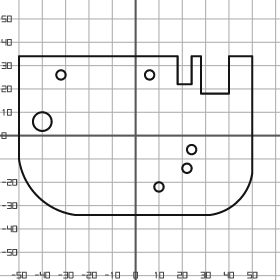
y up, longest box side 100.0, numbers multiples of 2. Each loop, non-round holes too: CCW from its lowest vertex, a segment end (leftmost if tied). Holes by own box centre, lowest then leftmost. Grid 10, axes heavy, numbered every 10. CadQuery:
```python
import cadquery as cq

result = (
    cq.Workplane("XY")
    .moveTo(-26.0, -34.0)
    .lineTo(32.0, -34.0)
    .threePointArc((44.0, -28.0), (50.0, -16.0))
    .lineTo(50.0, 34.0)
    .lineTo(40.0, 34.0)
    .lineTo(40.0, 18.0)
    .lineTo(28.0, 18.0)
    .lineTo(28.0, 34.0)
    .lineTo(24.0, 34.0)
    .lineTo(24.0, 22.0)
    .lineTo(18.0, 22.0)
    .lineTo(18.0, 34.0)
    .lineTo(-50.0, 34.0)
    .lineTo(-50.0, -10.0)
    .threePointArc((-42.0, -26.0), (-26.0, -34.0))
    .close()
    .moveTo(10.0, -22.0)
    .circle(2.0)
    .moveTo(22.0, -14.0)
    .circle(2.0)
    .moveTo(24.0, -6.0)
    .circle(2.0)
    .moveTo(-40.0, 6.0)
    .circle(4.0)
    .moveTo(-32.0, 26.0)
    .circle(2.0)
    .moveTo(6.0, 26.0)
    .circle(2.0)
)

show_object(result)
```